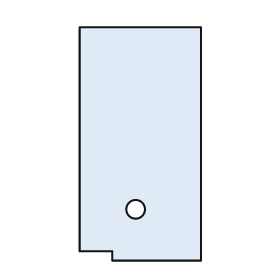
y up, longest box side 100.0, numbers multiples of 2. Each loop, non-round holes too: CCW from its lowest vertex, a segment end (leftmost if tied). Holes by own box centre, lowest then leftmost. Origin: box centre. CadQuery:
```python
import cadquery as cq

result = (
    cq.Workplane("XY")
    .moveTo(-12.0, -50.0)
    .lineTo(26.0, -50.0)
    .lineTo(26.0, 50.0)
    .lineTo(-26.0, 50.0)
    .lineTo(-26.0, -46.0)
    .lineTo(-12.0, -46.0)
    .close()
    .moveTo(-2.0, -28.0)
    .circle(4.0)
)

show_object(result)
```